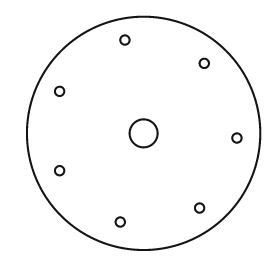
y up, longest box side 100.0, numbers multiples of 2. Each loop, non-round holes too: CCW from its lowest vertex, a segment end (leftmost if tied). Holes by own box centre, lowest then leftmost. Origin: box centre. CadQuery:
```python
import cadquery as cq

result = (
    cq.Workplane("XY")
    .moveTo(0.0, 0.0)
    .circle(50.0)
    .moveTo(-10.0, -38.0)
    .circle(2.0)
    .moveTo(24.0, -32.0)
    .circle(2.0)
    .moveTo(-36.0, -16.0)
    .circle(2.0)
    .moveTo(40.0, -2.0)
    .circle(2.0)
    .moveTo(0.0, 0.0)
    .circle(6.0)
    .moveTo(-36.0, 18.0)
    .circle(2.0)
    .moveTo(26.0, 30.0)
    .circle(2.0)
    .moveTo(-8.0, 40.0)
    .circle(2.0)
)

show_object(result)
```